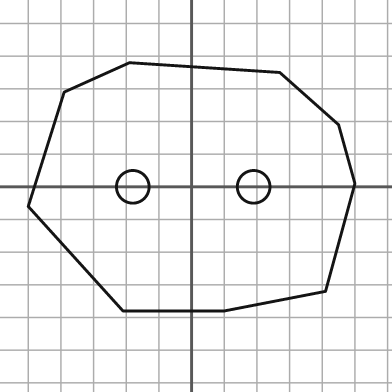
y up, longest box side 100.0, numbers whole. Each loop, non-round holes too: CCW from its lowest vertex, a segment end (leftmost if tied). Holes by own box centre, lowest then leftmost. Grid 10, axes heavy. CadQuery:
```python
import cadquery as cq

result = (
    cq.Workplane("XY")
    .moveTo(-21.0, -38.0)
    .lineTo(10.0, -38.0)
    .lineTo(41.0, -32.0)
    .lineTo(50.0, 1.0)
    .lineTo(45.0, 19.0)
    .lineTo(27.0, 35.0)
    .lineTo(-19.0, 38.0)
    .lineTo(-39.0, 29.0)
    .lineTo(-50.0, -6.0)
    .close()
    .moveTo(-18.0, 0.0)
    .circle(5.0)
    .moveTo(19.0, 0.0)
    .circle(5.0)
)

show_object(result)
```